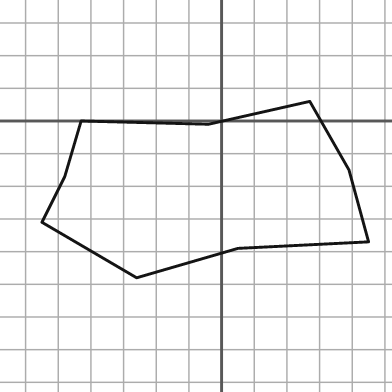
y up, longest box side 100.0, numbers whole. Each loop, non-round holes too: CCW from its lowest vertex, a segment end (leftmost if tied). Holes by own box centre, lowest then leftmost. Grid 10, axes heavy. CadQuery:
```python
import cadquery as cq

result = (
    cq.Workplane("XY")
    .moveTo(-26.0, -48.0)
    .lineTo(5.0, -39.0)
    .lineTo(45.0, -37.0)
    .lineTo(39.0, -15.0)
    .lineTo(27.0, 6.0)
    .lineTo(-4.0, -1.0)
    .lineTo(-43.0, 0.0)
    .lineTo(-48.0, -17.0)
    .lineTo(-55.0, -31.0)
    .close()
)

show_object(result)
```